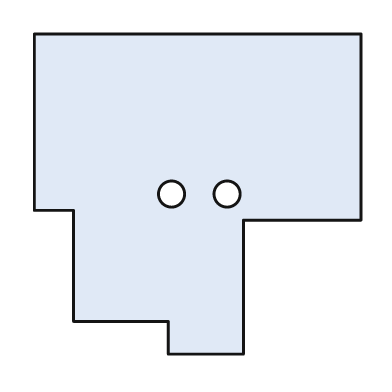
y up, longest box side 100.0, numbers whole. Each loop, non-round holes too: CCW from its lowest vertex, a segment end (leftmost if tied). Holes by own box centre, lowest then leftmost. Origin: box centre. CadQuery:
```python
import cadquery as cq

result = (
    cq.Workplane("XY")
    .moveTo(-9.0, -49.0)
    .lineTo(14.0, -49.0)
    .lineTo(14.0, -8.0)
    .lineTo(50.0, -8.0)
    .lineTo(50.0, 49.0)
    .lineTo(-50.0, 49.0)
    .lineTo(-50.0, -5.0)
    .lineTo(-38.0, -5.0)
    .lineTo(-38.0, -39.0)
    .lineTo(-9.0, -39.0)
    .close()
    .moveTo(-8.0, 0.0)
    .circle(4.0)
    .moveTo(9.0, 0.0)
    .circle(4.0)
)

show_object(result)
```